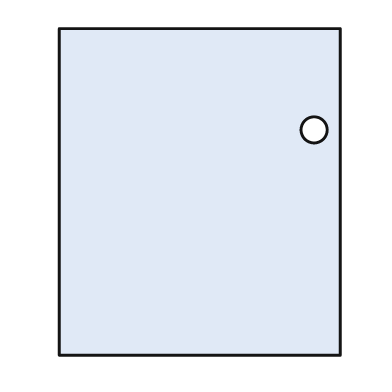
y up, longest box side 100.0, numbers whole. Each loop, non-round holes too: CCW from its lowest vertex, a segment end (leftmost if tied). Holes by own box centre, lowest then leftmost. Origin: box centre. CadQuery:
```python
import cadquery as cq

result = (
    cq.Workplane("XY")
    .moveTo(-43.0, -50.0)
    .lineTo(43.0, -50.0)
    .lineTo(43.0, 50.0)
    .lineTo(-43.0, 50.0)
    .close()
    .moveTo(35.0, 19.0)
    .circle(4.0)
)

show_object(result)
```